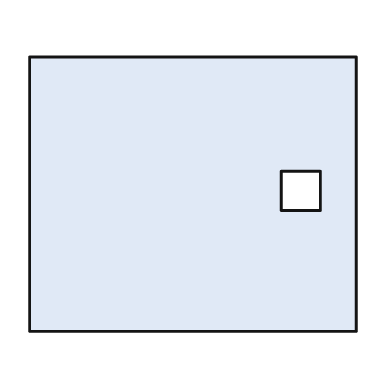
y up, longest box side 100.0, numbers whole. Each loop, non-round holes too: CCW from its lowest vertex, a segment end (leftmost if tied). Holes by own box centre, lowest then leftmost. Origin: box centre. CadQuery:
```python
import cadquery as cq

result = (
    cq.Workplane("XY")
    .moveTo(-50.0, -42.0)
    .lineTo(50.0, -42.0)
    .lineTo(50.0, 42.0)
    .lineTo(-50.0, 42.0)
    .close()
    .moveTo(27.0, -5.0)
    .lineTo(39.0, -5.0)
    .lineTo(39.0, 7.0)
    .lineTo(27.0, 7.0)
    .close()
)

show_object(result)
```